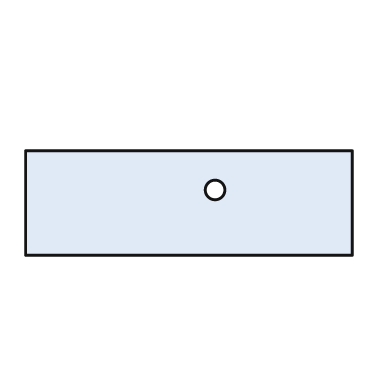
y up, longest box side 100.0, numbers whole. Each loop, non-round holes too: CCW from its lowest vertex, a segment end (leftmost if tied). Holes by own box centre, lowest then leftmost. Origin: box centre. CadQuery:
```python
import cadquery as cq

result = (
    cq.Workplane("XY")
    .moveTo(-50.0, -16.0)
    .lineTo(50.0, -16.0)
    .lineTo(50.0, 16.0)
    .lineTo(-50.0, 16.0)
    .close()
    .moveTo(8.0, 4.0)
    .circle(3.0)
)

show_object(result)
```